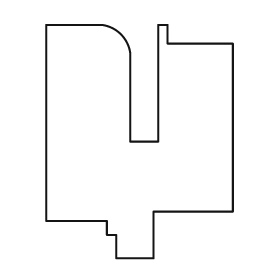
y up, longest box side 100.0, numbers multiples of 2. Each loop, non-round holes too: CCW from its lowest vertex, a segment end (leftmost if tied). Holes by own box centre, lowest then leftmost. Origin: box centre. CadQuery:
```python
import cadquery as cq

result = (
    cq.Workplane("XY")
    .moveTo(-10.0, -50.0)
    .lineTo(6.0, -50.0)
    .lineTo(6.0, -30.0)
    .lineTo(40.0, -30.0)
    .lineTo(40.0, 42.0)
    .lineTo(12.0, 42.0)
    .lineTo(12.0, 50.0)
    .lineTo(8.0, 50.0)
    .lineTo(8.0, 0.0)
    .lineTo(-4.0, 0.0)
    .lineTo(-4.0, 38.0)
    .threePointArc((-8.0, 46.0), (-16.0, 50.0))
    .lineTo(-40.0, 50.0)
    .lineTo(-40.0, -34.0)
    .lineTo(-14.0, -34.0)
    .lineTo(-14.0, -40.0)
    .lineTo(-10.0, -40.0)
    .close()
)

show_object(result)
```